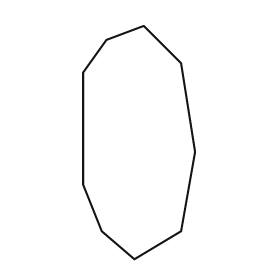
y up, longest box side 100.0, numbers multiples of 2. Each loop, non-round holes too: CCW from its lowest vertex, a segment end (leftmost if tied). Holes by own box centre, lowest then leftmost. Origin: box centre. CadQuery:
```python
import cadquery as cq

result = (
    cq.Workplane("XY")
    .moveTo(-2.0, -50.0)
    .lineTo(18.0, -38.0)
    .lineTo(24.0, -4.0)
    .lineTo(18.0, 34.0)
    .lineTo(2.0, 50.0)
    .lineTo(-14.0, 44.0)
    .lineTo(-24.0, 30.0)
    .lineTo(-24.0, -18.0)
    .lineTo(-16.0, -38.0)
    .close()
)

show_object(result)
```